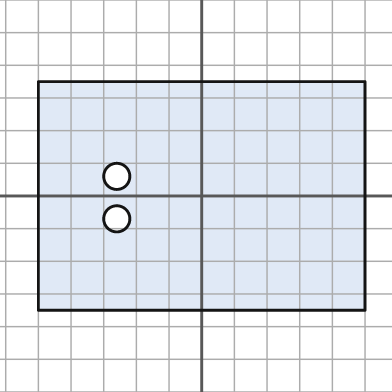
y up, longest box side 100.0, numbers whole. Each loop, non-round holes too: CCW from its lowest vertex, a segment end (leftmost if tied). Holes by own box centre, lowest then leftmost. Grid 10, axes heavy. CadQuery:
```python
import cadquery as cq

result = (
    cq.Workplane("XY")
    .moveTo(-50.0, -35.0)
    .lineTo(50.0, -35.0)
    .lineTo(50.0, 35.0)
    .lineTo(-50.0, 35.0)
    .close()
    .moveTo(-26.0, -7.0)
    .circle(4.0)
    .moveTo(-26.0, 6.0)
    .circle(4.0)
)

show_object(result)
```